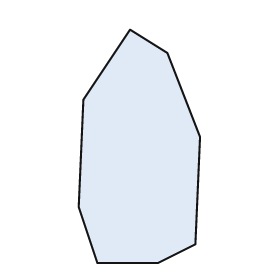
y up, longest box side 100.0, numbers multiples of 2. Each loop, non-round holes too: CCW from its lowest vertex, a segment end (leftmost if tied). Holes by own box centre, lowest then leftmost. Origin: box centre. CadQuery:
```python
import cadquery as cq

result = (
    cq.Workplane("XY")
    .moveTo(-18.0, -50.0)
    .lineTo(8.0, -50.0)
    .lineTo(24.0, -42.0)
    .lineTo(26.0, 4.0)
    .lineTo(12.0, 40.0)
    .lineTo(-4.0, 50.0)
    .lineTo(-24.0, 20.0)
    .lineTo(-26.0, -26.0)
    .close()
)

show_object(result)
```